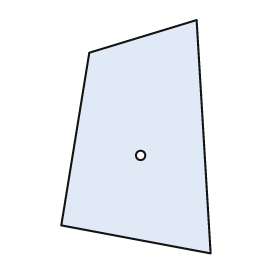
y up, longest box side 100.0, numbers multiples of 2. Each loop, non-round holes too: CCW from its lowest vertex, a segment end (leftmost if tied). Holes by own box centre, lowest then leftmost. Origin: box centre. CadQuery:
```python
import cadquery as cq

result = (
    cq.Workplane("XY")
    .moveTo(32.0, -50.0)
    .lineTo(26.0, 50.0)
    .lineTo(-20.0, 36.0)
    .lineTo(-32.0, -38.0)
    .close()
    .moveTo(2.0, -8.0)
    .circle(2.0)
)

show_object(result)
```